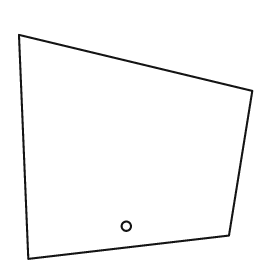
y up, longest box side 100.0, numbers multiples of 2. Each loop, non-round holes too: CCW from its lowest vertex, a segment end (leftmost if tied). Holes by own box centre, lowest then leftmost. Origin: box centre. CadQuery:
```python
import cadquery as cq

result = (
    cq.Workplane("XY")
    .moveTo(-46.0, -48.0)
    .lineTo(40.0, -38.0)
    .lineTo(50.0, 24.0)
    .lineTo(-50.0, 48.0)
    .close()
    .moveTo(-4.0, -34.0)
    .circle(2.0)
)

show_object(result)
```